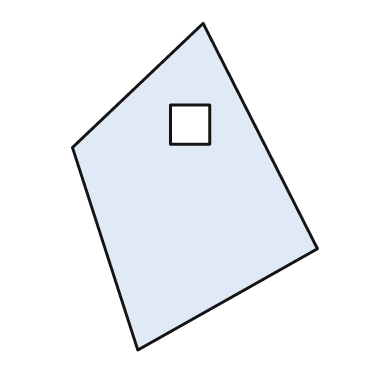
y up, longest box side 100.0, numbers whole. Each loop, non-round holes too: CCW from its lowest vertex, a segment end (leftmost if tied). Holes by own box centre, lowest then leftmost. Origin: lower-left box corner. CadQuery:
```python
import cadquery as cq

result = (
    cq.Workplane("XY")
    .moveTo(20.0, 0.0)
    .lineTo(75.0, 31.0)
    .lineTo(40.0, 100.0)
    .lineTo(0.0, 62.0)
    .close()
    .moveTo(30.0, 63.0)
    .lineTo(42.0, 63.0)
    .lineTo(42.0, 75.0)
    .lineTo(30.0, 75.0)
    .close()
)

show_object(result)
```